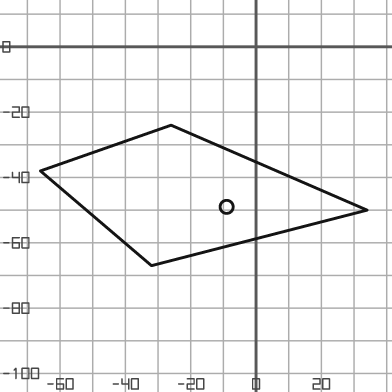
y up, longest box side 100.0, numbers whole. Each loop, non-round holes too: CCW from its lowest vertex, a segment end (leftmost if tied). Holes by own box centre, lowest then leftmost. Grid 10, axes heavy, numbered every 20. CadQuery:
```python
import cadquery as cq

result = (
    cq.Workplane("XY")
    .moveTo(-32.0, -67.0)
    .lineTo(34.0, -50.0)
    .lineTo(-26.0, -24.0)
    .lineTo(-66.0, -38.0)
    .close()
    .moveTo(-9.0, -49.0)
    .circle(2.0)
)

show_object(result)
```